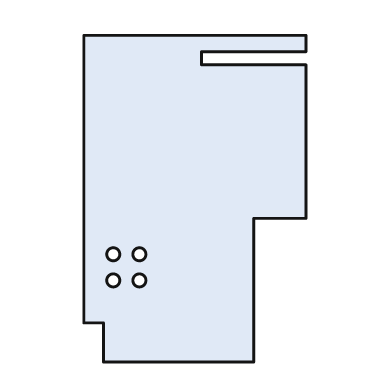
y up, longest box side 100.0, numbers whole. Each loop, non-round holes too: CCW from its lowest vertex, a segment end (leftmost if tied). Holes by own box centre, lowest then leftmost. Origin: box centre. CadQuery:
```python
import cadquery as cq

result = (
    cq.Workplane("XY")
    .moveTo(-28.0, -50.0)
    .lineTo(18.0, -50.0)
    .lineTo(18.0, -6.0)
    .lineTo(34.0, -6.0)
    .lineTo(34.0, 41.0)
    .lineTo(2.0, 41.0)
    .lineTo(2.0, 45.0)
    .lineTo(34.0, 45.0)
    .lineTo(34.0, 50.0)
    .lineTo(-34.0, 50.0)
    .lineTo(-34.0, -38.0)
    .lineTo(-28.0, -38.0)
    .close()
    .moveTo(-25.0, -25.0)
    .circle(2.0)
    .moveTo(-17.0, -25.0)
    .circle(2.0)
    .moveTo(-25.0, -17.0)
    .circle(2.0)
    .moveTo(-17.0, -17.0)
    .circle(2.0)
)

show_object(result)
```